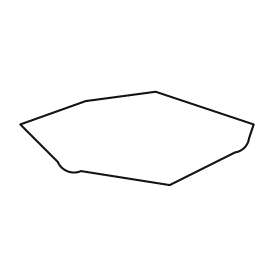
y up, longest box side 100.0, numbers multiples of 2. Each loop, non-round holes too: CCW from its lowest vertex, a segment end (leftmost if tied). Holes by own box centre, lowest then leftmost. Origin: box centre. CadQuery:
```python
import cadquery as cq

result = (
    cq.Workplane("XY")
    .moveTo(14.0, -20.0)
    .lineTo(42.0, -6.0)
    .threePointArc((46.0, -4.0), (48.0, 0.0))
    .lineTo(50.0, 6.0)
    .lineTo(8.0, 20.0)
    .lineTo(-22.0, 16.0)
    .lineTo(-50.0, 6.0)
    .lineTo(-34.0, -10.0)
    .threePointArc((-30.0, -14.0), (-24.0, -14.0))
    .close()
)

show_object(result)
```